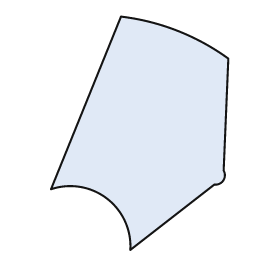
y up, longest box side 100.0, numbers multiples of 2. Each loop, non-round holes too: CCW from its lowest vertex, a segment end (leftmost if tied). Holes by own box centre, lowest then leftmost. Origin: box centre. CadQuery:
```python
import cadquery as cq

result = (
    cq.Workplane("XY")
    .moveTo(-4.0, -50.0)
    .lineTo(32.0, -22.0)
    .threePointArc((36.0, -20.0), (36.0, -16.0))
    .lineTo(38.0, 32.0)
    .threePointArc((16.0, 44.0), (-8.0, 50.0))
    .lineTo(-38.0, -24.0)
    .threePointArc((-14.0, -28.0), (-4.0, -50.0))
    .close()
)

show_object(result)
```